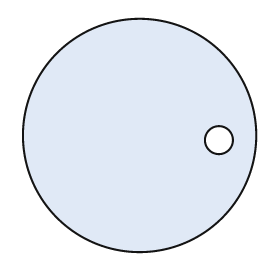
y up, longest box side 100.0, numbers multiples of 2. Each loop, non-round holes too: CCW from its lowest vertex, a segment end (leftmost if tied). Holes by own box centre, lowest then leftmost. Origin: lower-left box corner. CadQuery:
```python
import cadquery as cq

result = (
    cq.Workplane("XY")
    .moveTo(50.0, 50.0)
    .circle(50.0)
    .moveTo(84.0, 48.0)
    .circle(6.0)
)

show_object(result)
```